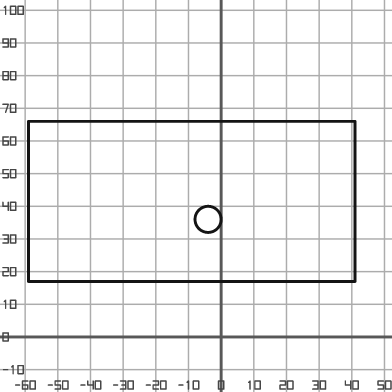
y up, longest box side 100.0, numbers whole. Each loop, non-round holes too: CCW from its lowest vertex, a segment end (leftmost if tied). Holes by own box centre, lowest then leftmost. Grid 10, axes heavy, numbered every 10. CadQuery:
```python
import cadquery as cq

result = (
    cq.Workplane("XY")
    .moveTo(-59.0, 17.0)
    .lineTo(41.0, 17.0)
    .lineTo(41.0, 66.0)
    .lineTo(-59.0, 66.0)
    .close()
    .moveTo(-4.0, 36.0)
    .circle(4.0)
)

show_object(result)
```